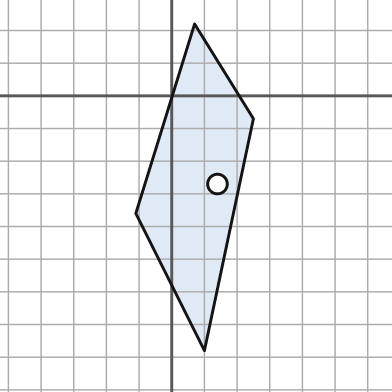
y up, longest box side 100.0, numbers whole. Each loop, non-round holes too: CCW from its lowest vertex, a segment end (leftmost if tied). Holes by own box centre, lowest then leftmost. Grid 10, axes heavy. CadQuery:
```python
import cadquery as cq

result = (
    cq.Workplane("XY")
    .moveTo(10.0, -78.0)
    .lineTo(25.0, -7.0)
    .lineTo(7.0, 22.0)
    .lineTo(-11.0, -36.0)
    .close()
    .moveTo(14.0, -27.0)
    .circle(3.0)
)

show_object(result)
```